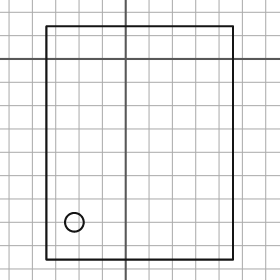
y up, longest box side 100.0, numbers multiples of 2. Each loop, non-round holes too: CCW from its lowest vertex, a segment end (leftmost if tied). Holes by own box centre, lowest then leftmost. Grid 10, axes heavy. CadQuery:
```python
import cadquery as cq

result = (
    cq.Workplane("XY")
    .moveTo(-34.0, -86.0)
    .lineTo(46.0, -86.0)
    .lineTo(46.0, 14.0)
    .lineTo(-34.0, 14.0)
    .close()
    .moveTo(-22.0, -70.0)
    .circle(4.0)
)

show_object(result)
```